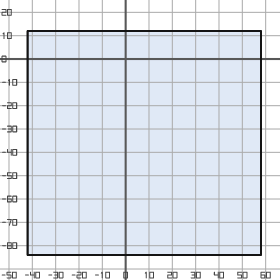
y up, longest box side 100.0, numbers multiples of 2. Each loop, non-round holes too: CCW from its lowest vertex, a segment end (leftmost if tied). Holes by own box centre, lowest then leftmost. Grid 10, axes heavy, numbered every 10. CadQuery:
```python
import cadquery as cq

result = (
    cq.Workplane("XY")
    .moveTo(-42.0, -84.0)
    .lineTo(58.0, -84.0)
    .lineTo(58.0, 12.0)
    .lineTo(-42.0, 12.0)
    .close()
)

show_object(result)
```